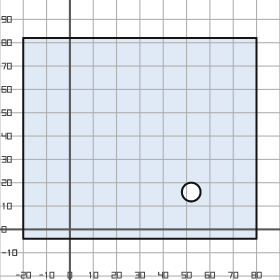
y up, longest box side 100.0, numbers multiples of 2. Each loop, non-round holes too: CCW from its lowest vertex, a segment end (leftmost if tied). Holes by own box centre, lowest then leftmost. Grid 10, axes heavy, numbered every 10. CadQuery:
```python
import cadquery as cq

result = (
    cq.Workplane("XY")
    .moveTo(-20.0, -4.0)
    .lineTo(80.0, -4.0)
    .lineTo(80.0, 82.0)
    .lineTo(-20.0, 82.0)
    .close()
    .moveTo(52.0, 16.0)
    .circle(4.0)
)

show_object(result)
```